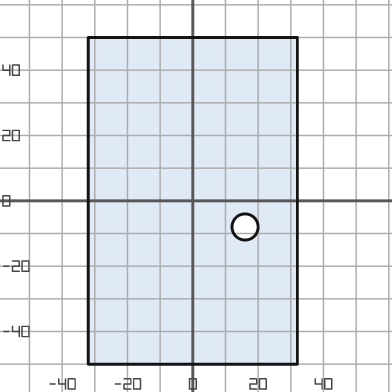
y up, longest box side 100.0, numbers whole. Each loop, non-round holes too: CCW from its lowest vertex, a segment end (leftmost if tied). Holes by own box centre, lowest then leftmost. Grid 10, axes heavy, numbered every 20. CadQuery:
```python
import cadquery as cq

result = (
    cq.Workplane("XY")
    .moveTo(-32.0, -50.0)
    .lineTo(32.0, -50.0)
    .lineTo(32.0, 50.0)
    .lineTo(-32.0, 50.0)
    .close()
    .moveTo(16.0, -8.0)
    .circle(4.0)
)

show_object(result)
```